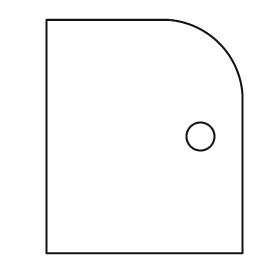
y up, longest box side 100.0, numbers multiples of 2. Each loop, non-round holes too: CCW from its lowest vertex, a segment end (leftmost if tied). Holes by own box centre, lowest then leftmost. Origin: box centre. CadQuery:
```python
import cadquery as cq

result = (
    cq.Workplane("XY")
    .moveTo(-42.0, -50.0)
    .lineTo(42.0, -50.0)
    .lineTo(42.0, 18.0)
    .threePointArc((32.0, 40.0), (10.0, 50.0))
    .lineTo(-42.0, 50.0)
    .close()
    .moveTo(24.0, 0.0)
    .circle(6.0)
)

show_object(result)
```